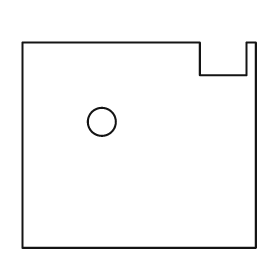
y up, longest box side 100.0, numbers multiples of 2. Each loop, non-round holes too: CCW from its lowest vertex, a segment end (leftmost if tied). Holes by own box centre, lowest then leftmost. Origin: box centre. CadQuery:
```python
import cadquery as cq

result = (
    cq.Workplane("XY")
    .moveTo(-50.0, -44.0)
    .lineTo(50.0, -44.0)
    .lineTo(50.0, 44.0)
    .lineTo(46.0, 44.0)
    .lineTo(46.0, 30.0)
    .lineTo(26.0, 30.0)
    .lineTo(26.0, 44.0)
    .lineTo(-50.0, 44.0)
    .close()
    .moveTo(-16.0, 10.0)
    .circle(6.0)
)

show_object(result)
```